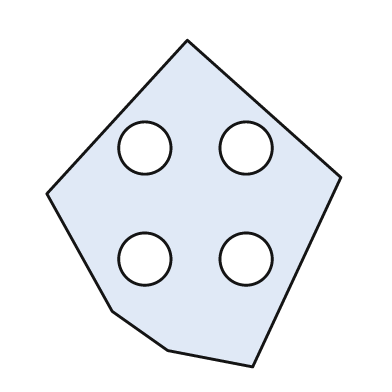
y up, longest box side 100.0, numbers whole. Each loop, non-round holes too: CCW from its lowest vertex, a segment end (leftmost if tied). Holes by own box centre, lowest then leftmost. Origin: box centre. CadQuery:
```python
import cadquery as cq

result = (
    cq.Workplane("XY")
    .moveTo(18.0, -50.0)
    .lineTo(45.0, 8.0)
    .lineTo(-2.0, 50.0)
    .lineTo(-45.0, 3.0)
    .lineTo(-25.0, -33.0)
    .lineTo(-8.0, -45.0)
    .close()
    .moveTo(-15.0, -17.0)
    .circle(8.0)
    .moveTo(16.0, -17.0)
    .circle(8.0)
    .moveTo(-15.0, 17.0)
    .circle(8.0)
    .moveTo(16.0, 17.0)
    .circle(8.0)
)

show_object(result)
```